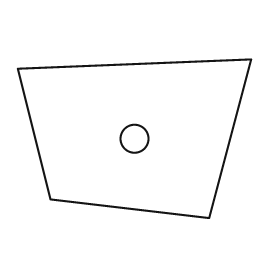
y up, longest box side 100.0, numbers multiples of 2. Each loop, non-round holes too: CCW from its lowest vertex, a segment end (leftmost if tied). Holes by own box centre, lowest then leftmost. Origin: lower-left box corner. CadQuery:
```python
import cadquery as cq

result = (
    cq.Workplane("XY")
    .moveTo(82.0, 0.0)
    .lineTo(100.0, 68.0)
    .lineTo(0.0, 64.0)
    .lineTo(14.0, 8.0)
    .close()
    .moveTo(50.0, 34.0)
    .circle(6.0)
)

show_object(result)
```